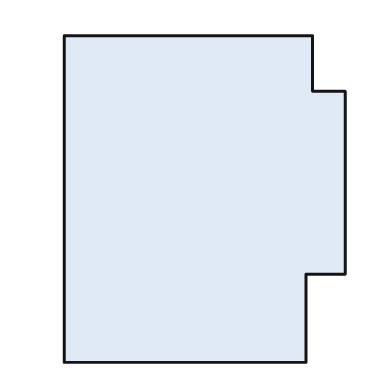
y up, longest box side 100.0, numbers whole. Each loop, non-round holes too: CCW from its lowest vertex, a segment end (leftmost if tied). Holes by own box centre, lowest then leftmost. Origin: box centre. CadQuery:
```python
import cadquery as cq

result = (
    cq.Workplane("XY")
    .moveTo(-43.0, -50.0)
    .lineTo(31.0, -50.0)
    .lineTo(31.0, -23.0)
    .lineTo(43.0, -23.0)
    .lineTo(43.0, 33.0)
    .lineTo(33.0, 33.0)
    .lineTo(33.0, 50.0)
    .lineTo(-43.0, 50.0)
    .close()
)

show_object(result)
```